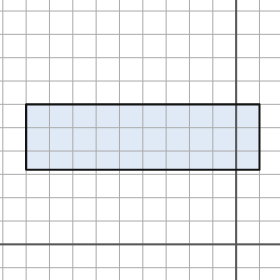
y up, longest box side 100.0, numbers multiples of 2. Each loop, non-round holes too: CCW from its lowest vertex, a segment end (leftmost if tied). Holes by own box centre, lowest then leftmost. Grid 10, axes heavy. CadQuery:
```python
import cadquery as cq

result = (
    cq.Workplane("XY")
    .moveTo(-90.0, 32.0)
    .lineTo(10.0, 32.0)
    .lineTo(10.0, 60.0)
    .lineTo(-90.0, 60.0)
    .close()
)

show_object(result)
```